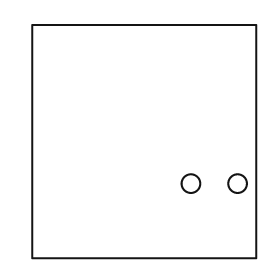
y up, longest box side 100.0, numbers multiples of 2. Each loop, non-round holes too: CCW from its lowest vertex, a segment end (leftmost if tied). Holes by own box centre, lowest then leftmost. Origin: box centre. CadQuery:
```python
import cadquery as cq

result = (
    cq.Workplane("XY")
    .moveTo(-48.0, -50.0)
    .lineTo(48.0, -50.0)
    .lineTo(48.0, 50.0)
    .lineTo(-48.0, 50.0)
    .close()
    .moveTo(20.0, -18.0)
    .circle(4.0)
    .moveTo(40.0, -18.0)
    .circle(4.0)
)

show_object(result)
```